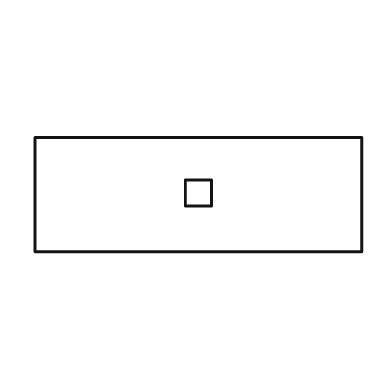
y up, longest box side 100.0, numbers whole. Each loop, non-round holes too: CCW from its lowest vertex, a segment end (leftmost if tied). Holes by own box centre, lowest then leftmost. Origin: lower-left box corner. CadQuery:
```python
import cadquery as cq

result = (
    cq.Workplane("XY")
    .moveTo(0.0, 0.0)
    .lineTo(100.0, 0.0)
    .lineTo(100.0, 35.0)
    .lineTo(0.0, 35.0)
    .close()
    .moveTo(46.0, 14.0)
    .lineTo(54.0, 14.0)
    .lineTo(54.0, 22.0)
    .lineTo(46.0, 22.0)
    .close()
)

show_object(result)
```